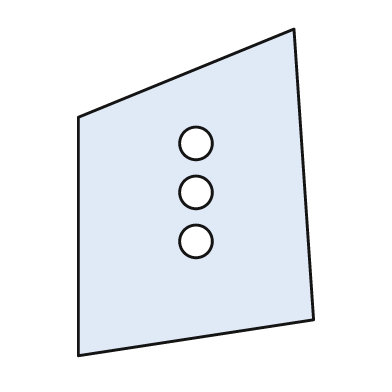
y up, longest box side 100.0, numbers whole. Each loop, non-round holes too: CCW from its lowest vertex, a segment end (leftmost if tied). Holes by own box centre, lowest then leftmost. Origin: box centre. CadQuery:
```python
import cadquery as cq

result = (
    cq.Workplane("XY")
    .moveTo(-36.0, -50.0)
    .lineTo(36.0, -39.0)
    .lineTo(30.0, 50.0)
    .lineTo(-36.0, 23.0)
    .close()
    .moveTo(0.0, -15.0)
    .circle(5.0)
    .moveTo(0.0, 0.0)
    .circle(5.0)
    .moveTo(0.0, 15.0)
    .circle(5.0)
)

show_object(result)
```